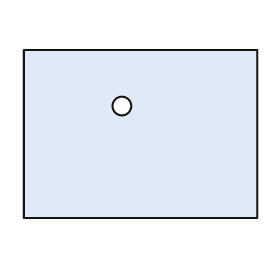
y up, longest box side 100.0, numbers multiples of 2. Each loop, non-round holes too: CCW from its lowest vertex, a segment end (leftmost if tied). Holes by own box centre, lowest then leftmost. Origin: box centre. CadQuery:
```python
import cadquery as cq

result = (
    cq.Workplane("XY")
    .moveTo(-50.0, -36.0)
    .lineTo(50.0, -36.0)
    .lineTo(50.0, 36.0)
    .lineTo(-50.0, 36.0)
    .close()
    .moveTo(-8.0, 12.0)
    .circle(4.0)
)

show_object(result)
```